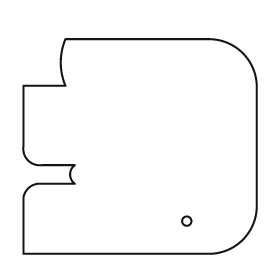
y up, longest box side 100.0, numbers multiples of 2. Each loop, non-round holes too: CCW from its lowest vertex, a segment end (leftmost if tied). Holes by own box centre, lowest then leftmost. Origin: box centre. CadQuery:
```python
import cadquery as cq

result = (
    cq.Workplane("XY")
    .moveTo(-50.0, -46.0)
    .lineTo(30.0, -46.0)
    .threePointArc((44.0, -40.0), (50.0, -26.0))
    .lineTo(50.0, 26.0)
    .threePointArc((44.0, 40.0), (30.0, 46.0))
    .lineTo(-32.0, 46.0)
    .threePointArc((-34.0, 36.0), (-32.0, 26.0))
    .lineTo(-50.0, 26.0)
    .lineTo(-50.0, 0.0)
    .threePointArc((-48.0, -6.0), (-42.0, -8.0))
    .lineTo(-28.0, -8.0)
    .threePointArc((-30.0, -12.0), (-28.0, -16.0))
    .lineTo(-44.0, -16.0)
    .threePointArc((-48.0, -18.0), (-50.0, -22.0))
    .close()
    .moveTo(20.0, -32.0)
    .circle(2.0)
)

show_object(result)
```